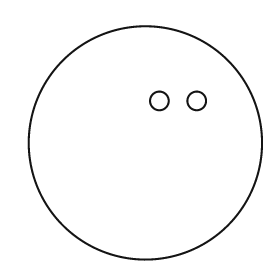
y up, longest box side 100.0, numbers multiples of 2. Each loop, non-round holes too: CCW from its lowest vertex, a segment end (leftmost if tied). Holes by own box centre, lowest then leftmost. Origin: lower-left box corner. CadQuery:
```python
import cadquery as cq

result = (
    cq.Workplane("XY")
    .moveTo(50.0, 50.0)
    .circle(50.0)
    .moveTo(56.0, 68.0)
    .circle(4.0)
    .moveTo(72.0, 68.0)
    .circle(4.0)
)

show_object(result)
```